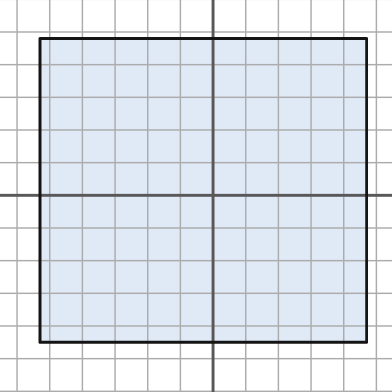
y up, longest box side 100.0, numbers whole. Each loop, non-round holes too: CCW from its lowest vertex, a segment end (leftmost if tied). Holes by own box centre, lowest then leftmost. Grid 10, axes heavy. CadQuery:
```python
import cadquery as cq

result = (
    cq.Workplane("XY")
    .moveTo(-53.0, -45.0)
    .lineTo(47.0, -45.0)
    .lineTo(47.0, 48.0)
    .lineTo(-53.0, 48.0)
    .close()
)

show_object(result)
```